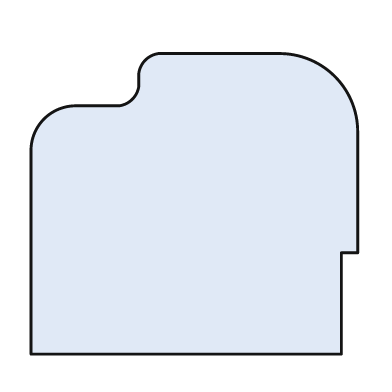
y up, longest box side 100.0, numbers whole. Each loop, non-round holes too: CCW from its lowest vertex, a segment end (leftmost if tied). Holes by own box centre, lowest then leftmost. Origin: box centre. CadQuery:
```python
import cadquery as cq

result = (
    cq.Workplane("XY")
    .moveTo(-50.0, -46.0)
    .lineTo(45.0, -46.0)
    .lineTo(45.0, -15.0)
    .lineTo(50.0, -15.0)
    .lineTo(50.0, 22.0)
    .threePointArc((43.0, 39.0), (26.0, 46.0))
    .lineTo(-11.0, 46.0)
    .threePointArc((-15.0, 44.0), (-17.0, 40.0))
    .lineTo(-17.0, 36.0)
    .threePointArc((-19.0, 32.0), (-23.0, 30.0))
    .lineTo(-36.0, 30.0)
    .threePointArc((-46.0, 26.0), (-50.0, 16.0))
    .close()
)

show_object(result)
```